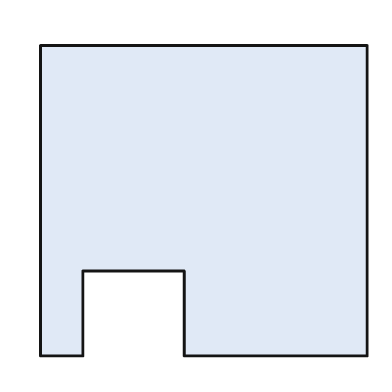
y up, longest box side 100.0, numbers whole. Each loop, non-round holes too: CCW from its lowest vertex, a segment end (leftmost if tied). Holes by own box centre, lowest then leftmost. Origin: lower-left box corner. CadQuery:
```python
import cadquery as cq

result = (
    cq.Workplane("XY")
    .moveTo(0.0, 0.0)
    .lineTo(13.0, 0.0)
    .lineTo(13.0, 26.0)
    .lineTo(44.0, 26.0)
    .lineTo(44.0, 0.0)
    .lineTo(100.0, 0.0)
    .lineTo(100.0, 95.0)
    .lineTo(0.0, 95.0)
    .close()
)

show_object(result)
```